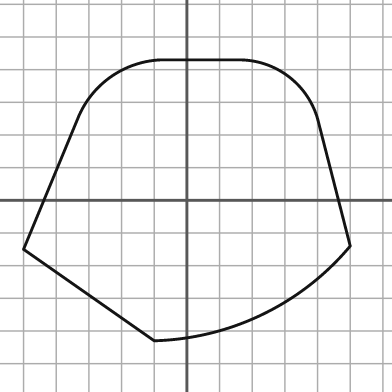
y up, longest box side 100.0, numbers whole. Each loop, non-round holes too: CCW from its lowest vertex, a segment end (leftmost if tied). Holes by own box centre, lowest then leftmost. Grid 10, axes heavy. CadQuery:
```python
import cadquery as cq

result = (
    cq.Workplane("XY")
    .moveTo(-10.0, -43.0)
    .threePointArc((23.0, -35.0), (50.0, -14.0))
    .lineTo(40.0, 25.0)
    .threePointArc((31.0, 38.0), (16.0, 43.0))
    .lineTo(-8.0, 43.0)
    .threePointArc((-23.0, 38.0), (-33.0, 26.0))
    .lineTo(-50.0, -15.0)
    .close()
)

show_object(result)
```